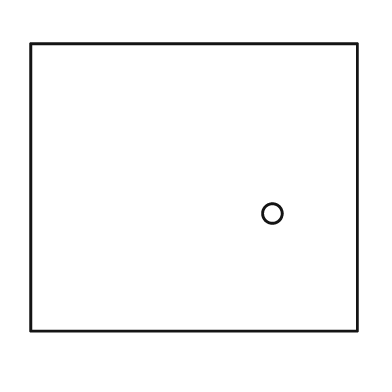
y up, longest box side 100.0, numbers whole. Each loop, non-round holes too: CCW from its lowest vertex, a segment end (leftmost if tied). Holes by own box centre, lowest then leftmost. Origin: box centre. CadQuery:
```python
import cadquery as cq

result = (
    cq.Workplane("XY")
    .moveTo(-50.0, -44.0)
    .lineTo(50.0, -44.0)
    .lineTo(50.0, 44.0)
    .lineTo(-50.0, 44.0)
    .close()
    .moveTo(24.0, -8.0)
    .circle(3.0)
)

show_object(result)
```